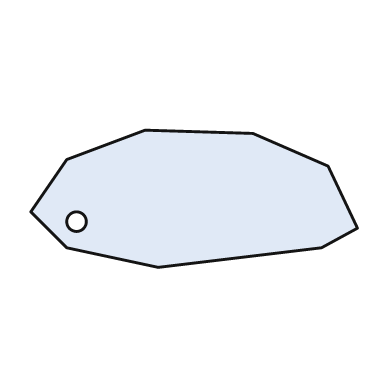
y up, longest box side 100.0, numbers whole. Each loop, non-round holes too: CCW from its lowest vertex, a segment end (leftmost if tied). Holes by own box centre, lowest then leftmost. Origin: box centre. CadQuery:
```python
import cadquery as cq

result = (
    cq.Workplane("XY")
    .moveTo(-11.0, -21.0)
    .lineTo(39.0, -15.0)
    .lineTo(50.0, -9.0)
    .lineTo(41.0, 10.0)
    .lineTo(18.0, 20.0)
    .lineTo(-15.0, 21.0)
    .lineTo(-39.0, 12.0)
    .lineTo(-50.0, -4.0)
    .lineTo(-39.0, -15.0)
    .close()
    .moveTo(-36.0, -7.0)
    .circle(3.0)
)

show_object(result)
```